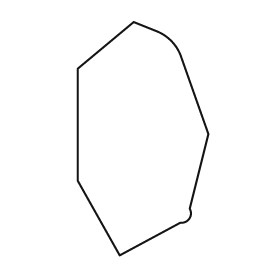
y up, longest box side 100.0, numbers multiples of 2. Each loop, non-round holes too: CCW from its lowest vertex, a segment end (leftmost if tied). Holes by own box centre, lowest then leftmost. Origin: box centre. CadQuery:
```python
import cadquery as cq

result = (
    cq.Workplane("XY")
    .moveTo(-10.0, -50.0)
    .lineTo(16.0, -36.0)
    .threePointArc((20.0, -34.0), (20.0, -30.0))
    .lineTo(28.0, 2.0)
    .lineTo(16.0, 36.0)
    .threePointArc((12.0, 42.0), (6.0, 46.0))
    .lineTo(-4.0, 50.0)
    .lineTo(-28.0, 30.0)
    .lineTo(-28.0, -18.0)
    .close()
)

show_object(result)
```